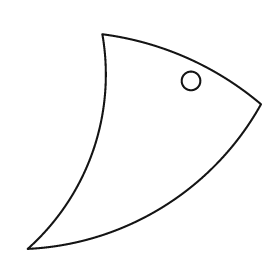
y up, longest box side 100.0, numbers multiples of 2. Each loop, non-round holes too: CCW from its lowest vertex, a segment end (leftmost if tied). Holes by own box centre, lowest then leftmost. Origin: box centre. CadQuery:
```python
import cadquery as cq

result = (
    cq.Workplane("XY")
    .moveTo(-50.0, -46.0)
    .threePointArc((8.0, -28.0), (50.0, 16.0))
    .threePointArc((18.0, 36.0), (-18.0, 46.0))
    .threePointArc((-22.0, -4.0), (-50.0, -46.0))
    .close()
    .moveTo(20.0, 26.0)
    .circle(4.0)
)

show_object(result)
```